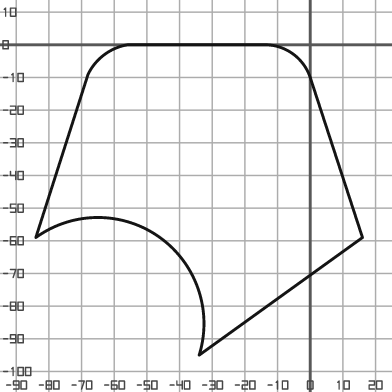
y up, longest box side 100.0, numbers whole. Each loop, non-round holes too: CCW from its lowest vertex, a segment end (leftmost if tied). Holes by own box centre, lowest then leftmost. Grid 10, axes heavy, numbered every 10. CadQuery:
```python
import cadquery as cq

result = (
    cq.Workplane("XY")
    .moveTo(-34.0, -95.0)
    .lineTo(16.0, -59.0)
    .lineTo(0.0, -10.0)
    .threePointArc((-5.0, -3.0), (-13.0, 0.0))
    .lineTo(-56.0, 0.0)
    .threePointArc((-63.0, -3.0), (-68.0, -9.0))
    .lineTo(-84.0, -59.0)
    .threePointArc((-46.0, -59.0), (-34.0, -95.0))
    .close()
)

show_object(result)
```